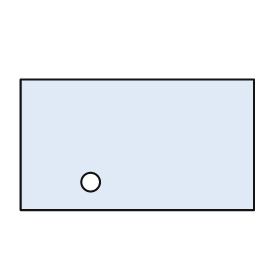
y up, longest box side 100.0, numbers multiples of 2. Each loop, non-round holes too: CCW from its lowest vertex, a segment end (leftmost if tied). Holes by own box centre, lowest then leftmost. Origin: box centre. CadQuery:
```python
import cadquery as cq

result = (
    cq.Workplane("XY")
    .moveTo(-50.0, -28.0)
    .lineTo(50.0, -28.0)
    .lineTo(50.0, 28.0)
    .lineTo(-50.0, 28.0)
    .close()
    .moveTo(-20.0, -16.0)
    .circle(4.0)
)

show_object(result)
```